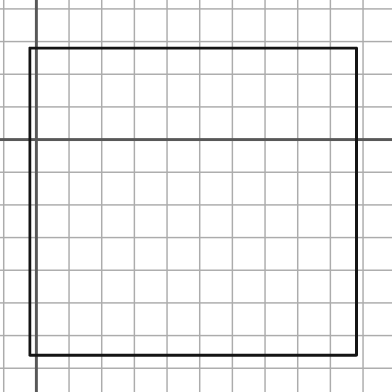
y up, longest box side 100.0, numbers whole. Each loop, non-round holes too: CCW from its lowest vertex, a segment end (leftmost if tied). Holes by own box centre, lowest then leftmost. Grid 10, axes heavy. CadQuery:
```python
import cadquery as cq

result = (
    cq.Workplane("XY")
    .moveTo(-2.0, -66.0)
    .lineTo(98.0, -66.0)
    .lineTo(98.0, 28.0)
    .lineTo(-2.0, 28.0)
    .close()
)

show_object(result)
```